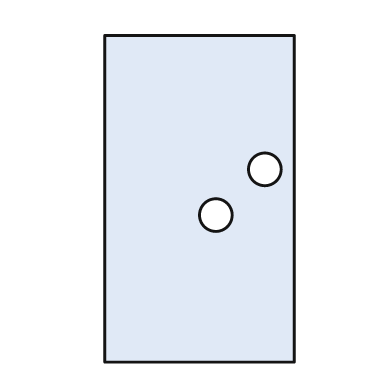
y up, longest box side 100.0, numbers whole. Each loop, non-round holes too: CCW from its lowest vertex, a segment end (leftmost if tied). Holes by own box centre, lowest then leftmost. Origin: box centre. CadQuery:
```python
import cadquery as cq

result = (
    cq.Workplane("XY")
    .moveTo(-29.0, -50.0)
    .lineTo(29.0, -50.0)
    .lineTo(29.0, 50.0)
    .lineTo(-29.0, 50.0)
    .close()
    .moveTo(5.0, -5.0)
    .circle(5.0)
    .moveTo(20.0, 9.0)
    .circle(5.0)
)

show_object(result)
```